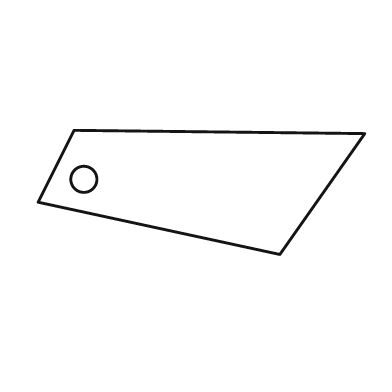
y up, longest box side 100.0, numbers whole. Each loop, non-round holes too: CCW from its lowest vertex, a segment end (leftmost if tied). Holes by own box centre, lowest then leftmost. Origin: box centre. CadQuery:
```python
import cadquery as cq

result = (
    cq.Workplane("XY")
    .moveTo(24.0, -19.0)
    .lineTo(50.0, 18.0)
    .lineTo(-39.0, 19.0)
    .lineTo(-50.0, -3.0)
    .close()
    .moveTo(-36.0, 4.0)
    .circle(4.0)
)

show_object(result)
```